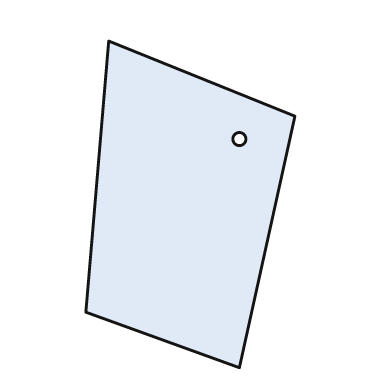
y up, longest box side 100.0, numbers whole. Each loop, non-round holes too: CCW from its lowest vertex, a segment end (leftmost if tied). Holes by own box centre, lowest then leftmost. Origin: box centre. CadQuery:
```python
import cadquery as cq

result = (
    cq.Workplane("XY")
    .moveTo(15.0, -50.0)
    .lineTo(32.0, 27.0)
    .lineTo(-25.0, 50.0)
    .lineTo(-32.0, -33.0)
    .close()
    .moveTo(15.0, 20.0)
    .circle(2.0)
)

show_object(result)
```